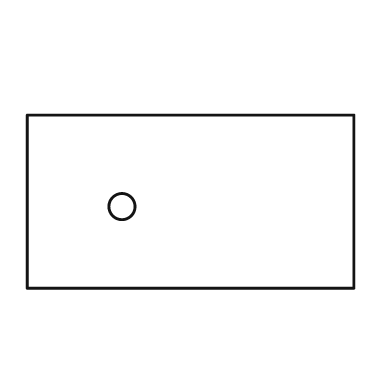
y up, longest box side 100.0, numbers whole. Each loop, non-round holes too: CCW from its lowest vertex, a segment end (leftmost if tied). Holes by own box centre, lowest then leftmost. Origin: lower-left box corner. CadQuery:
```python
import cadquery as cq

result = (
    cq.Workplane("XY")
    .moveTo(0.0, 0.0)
    .lineTo(100.0, 0.0)
    .lineTo(100.0, 53.0)
    .lineTo(0.0, 53.0)
    .close()
    .moveTo(29.0, 25.0)
    .circle(4.0)
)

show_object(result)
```